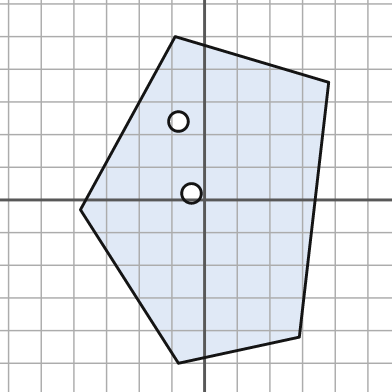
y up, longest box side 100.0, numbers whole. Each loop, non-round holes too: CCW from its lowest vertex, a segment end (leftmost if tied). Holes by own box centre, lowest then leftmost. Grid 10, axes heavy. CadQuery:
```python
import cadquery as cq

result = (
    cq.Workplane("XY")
    .moveTo(-8.0, -50.0)
    .lineTo(29.0, -42.0)
    .lineTo(38.0, 36.0)
    .lineTo(-9.0, 50.0)
    .lineTo(-38.0, -3.0)
    .close()
    .moveTo(-4.0, 2.0)
    .circle(3.0)
    .moveTo(-8.0, 24.0)
    .circle(3.0)
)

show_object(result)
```